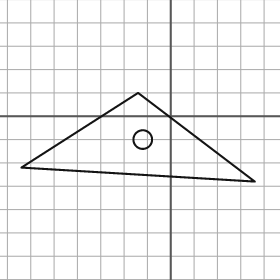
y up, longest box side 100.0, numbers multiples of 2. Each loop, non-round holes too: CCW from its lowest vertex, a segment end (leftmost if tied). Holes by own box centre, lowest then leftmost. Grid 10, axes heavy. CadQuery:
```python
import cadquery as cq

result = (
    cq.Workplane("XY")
    .moveTo(36.0, -28.0)
    .lineTo(-14.0, 10.0)
    .lineTo(-64.0, -22.0)
    .close()
    .moveTo(-12.0, -10.0)
    .circle(4.0)
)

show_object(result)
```